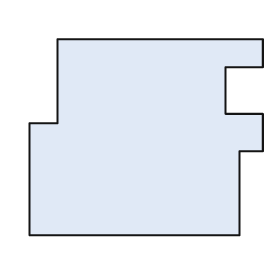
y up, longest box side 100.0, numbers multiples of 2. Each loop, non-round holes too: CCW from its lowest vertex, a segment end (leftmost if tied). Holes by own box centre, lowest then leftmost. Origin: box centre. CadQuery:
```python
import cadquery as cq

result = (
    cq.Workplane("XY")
    .moveTo(-50.0, -42.0)
    .lineTo(40.0, -42.0)
    .lineTo(40.0, -6.0)
    .lineTo(50.0, -6.0)
    .lineTo(50.0, 10.0)
    .lineTo(34.0, 10.0)
    .lineTo(34.0, 30.0)
    .lineTo(50.0, 30.0)
    .lineTo(50.0, 42.0)
    .lineTo(-38.0, 42.0)
    .lineTo(-38.0, 6.0)
    .lineTo(-50.0, 6.0)
    .close()
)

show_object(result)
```